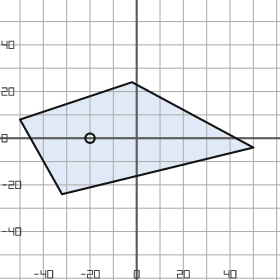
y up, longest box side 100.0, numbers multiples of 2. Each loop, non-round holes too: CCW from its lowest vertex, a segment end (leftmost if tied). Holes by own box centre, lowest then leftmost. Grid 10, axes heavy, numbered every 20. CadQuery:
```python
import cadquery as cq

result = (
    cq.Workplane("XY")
    .moveTo(-32.0, -24.0)
    .lineTo(50.0, -4.0)
    .lineTo(-2.0, 24.0)
    .lineTo(-50.0, 8.0)
    .close()
    .moveTo(-20.0, 0.0)
    .circle(2.0)
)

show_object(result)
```